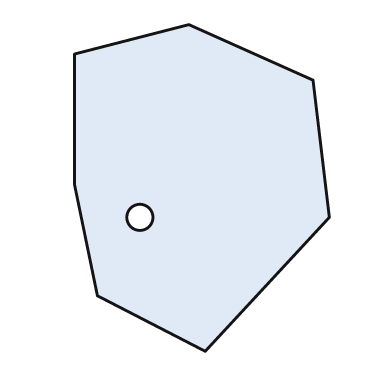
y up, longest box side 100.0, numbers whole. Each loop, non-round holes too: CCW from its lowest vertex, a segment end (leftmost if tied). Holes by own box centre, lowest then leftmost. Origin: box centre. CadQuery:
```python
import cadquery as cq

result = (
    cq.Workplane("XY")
    .moveTo(1.0, -50.0)
    .lineTo(39.0, -9.0)
    .lineTo(34.0, 33.0)
    .lineTo(-4.0, 50.0)
    .lineTo(-39.0, 41.0)
    .lineTo(-39.0, 1.0)
    .lineTo(-32.0, -33.0)
    .close()
    .moveTo(-19.0, -9.0)
    .circle(4.0)
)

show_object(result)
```